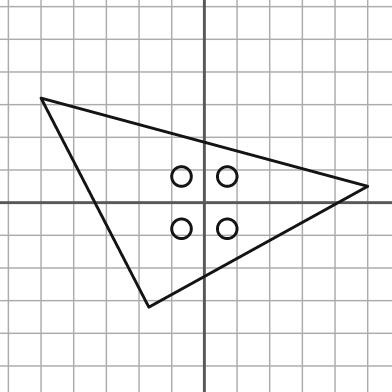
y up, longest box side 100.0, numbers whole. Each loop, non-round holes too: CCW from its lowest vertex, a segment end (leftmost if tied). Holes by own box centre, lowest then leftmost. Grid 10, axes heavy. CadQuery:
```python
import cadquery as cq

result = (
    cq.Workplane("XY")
    .moveTo(-17.0, -32.0)
    .lineTo(50.0, 5.0)
    .lineTo(-50.0, 32.0)
    .close()
    .moveTo(-7.0, -8.0)
    .circle(3.0)
    .moveTo(7.0, -8.0)
    .circle(3.0)
    .moveTo(-7.0, 8.0)
    .circle(3.0)
    .moveTo(7.0, 8.0)
    .circle(3.0)
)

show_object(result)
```